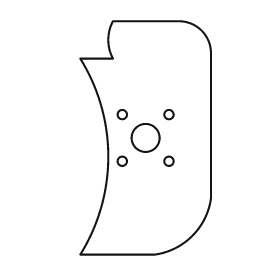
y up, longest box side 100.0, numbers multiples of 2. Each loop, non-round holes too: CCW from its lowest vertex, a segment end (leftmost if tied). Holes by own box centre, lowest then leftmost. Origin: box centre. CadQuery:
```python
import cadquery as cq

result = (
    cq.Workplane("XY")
    .moveTo(-28.0, -50.0)
    .lineTo(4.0, -50.0)
    .threePointArc((20.0, -42.0), (28.0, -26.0))
    .lineTo(28.0, 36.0)
    .threePointArc((24.0, 46.0), (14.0, 50.0))
    .lineTo(-14.0, 50.0)
    .threePointArc((-16.0, 42.0), (-14.0, 34.0))
    .lineTo(-28.0, 34.0)
    .threePointArc((-16.0, -8.0), (-28.0, -50.0))
    .close()
    .moveTo(-10.0, -10.0)
    .circle(2.0)
    .moveTo(10.0, -10.0)
    .circle(2.0)
    .moveTo(0.0, 0.0)
    .circle(6.0)
    .moveTo(-10.0, 10.0)
    .circle(2.0)
    .moveTo(10.0, 10.0)
    .circle(2.0)
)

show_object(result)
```